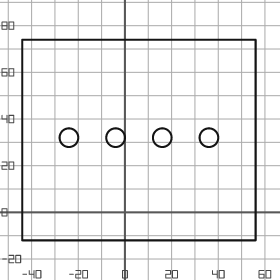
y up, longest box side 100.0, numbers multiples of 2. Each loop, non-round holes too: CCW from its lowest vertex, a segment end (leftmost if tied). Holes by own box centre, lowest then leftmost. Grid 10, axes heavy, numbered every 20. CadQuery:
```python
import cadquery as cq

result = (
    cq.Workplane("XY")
    .moveTo(-44.0, -12.0)
    .lineTo(56.0, -12.0)
    .lineTo(56.0, 74.0)
    .lineTo(-44.0, 74.0)
    .close()
    .moveTo(-24.0, 32.0)
    .circle(4.0)
    .moveTo(-4.0, 32.0)
    .circle(4.0)
    .moveTo(16.0, 32.0)
    .circle(4.0)
    .moveTo(36.0, 32.0)
    .circle(4.0)
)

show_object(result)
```